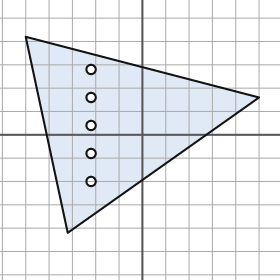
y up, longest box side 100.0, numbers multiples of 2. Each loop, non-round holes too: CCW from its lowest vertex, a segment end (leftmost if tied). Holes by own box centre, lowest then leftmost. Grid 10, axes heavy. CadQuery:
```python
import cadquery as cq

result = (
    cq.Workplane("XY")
    .moveTo(-32.0, -42.0)
    .lineTo(50.0, 16.0)
    .lineTo(-50.0, 42.0)
    .close()
    .moveTo(-22.0, -20.0)
    .circle(2.0)
    .moveTo(-22.0, -8.0)
    .circle(2.0)
    .moveTo(-22.0, 4.0)
    .circle(2.0)
    .moveTo(-22.0, 16.0)
    .circle(2.0)
    .moveTo(-22.0, 28.0)
    .circle(2.0)
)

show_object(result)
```